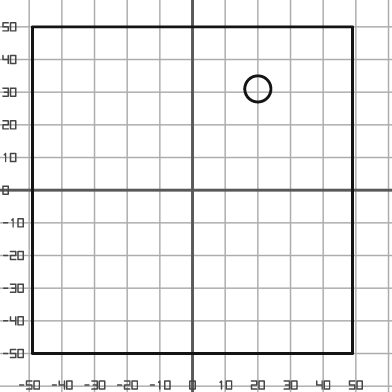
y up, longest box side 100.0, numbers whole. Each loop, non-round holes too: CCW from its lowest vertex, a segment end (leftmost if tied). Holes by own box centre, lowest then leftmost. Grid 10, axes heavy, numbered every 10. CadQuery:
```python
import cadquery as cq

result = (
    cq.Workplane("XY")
    .moveTo(-49.0, -50.0)
    .lineTo(49.0, -50.0)
    .lineTo(49.0, 50.0)
    .lineTo(-49.0, 50.0)
    .close()
    .moveTo(20.0, 31.0)
    .circle(4.0)
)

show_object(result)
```